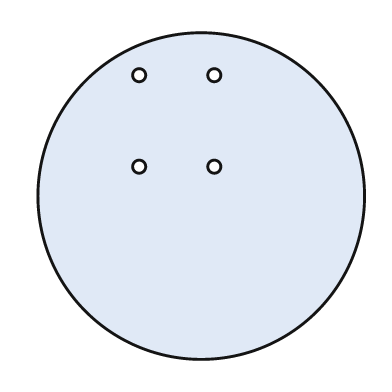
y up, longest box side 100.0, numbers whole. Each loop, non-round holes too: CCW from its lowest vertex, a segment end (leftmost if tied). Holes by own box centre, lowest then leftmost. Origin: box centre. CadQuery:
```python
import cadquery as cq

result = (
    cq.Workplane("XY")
    .moveTo(0.0, 0.0)
    .circle(50.0)
    .moveTo(-19.0, 9.0)
    .circle(2.0)
    .moveTo(4.0, 9.0)
    .circle(2.0)
    .moveTo(-19.0, 37.0)
    .circle(2.0)
    .moveTo(4.0, 37.0)
    .circle(2.0)
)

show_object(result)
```